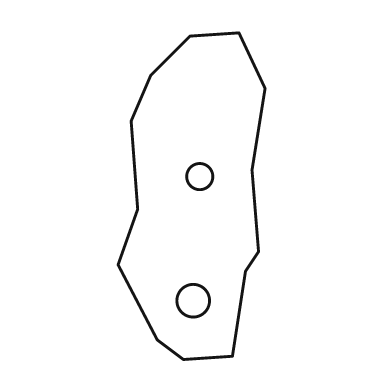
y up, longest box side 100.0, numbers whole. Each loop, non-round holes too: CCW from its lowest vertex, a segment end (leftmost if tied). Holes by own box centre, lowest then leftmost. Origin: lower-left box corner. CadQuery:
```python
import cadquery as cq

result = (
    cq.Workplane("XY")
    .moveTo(20.0, 0.0)
    .lineTo(35.0, 1.0)
    .lineTo(39.0, 27.0)
    .lineTo(43.0, 33.0)
    .lineTo(41.0, 58.0)
    .lineTo(45.0, 83.0)
    .lineTo(37.0, 100.0)
    .lineTo(22.0, 99.0)
    .lineTo(10.0, 87.0)
    .lineTo(4.0, 73.0)
    .lineTo(6.0, 46.0)
    .lineTo(0.0, 29.0)
    .lineTo(12.0, 6.0)
    .close()
    .moveTo(23.0, 18.0)
    .circle(5.0)
    .moveTo(25.0, 56.0)
    .circle(4.0)
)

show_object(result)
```